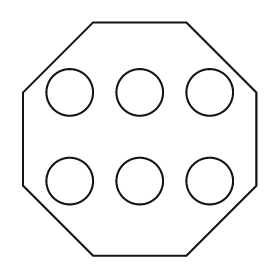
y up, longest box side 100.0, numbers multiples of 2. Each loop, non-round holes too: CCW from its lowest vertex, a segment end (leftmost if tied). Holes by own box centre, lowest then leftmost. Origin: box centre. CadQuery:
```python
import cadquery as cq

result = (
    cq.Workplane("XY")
    .moveTo(-20.0, -50.0)
    .lineTo(20.0, -50.0)
    .lineTo(50.0, -20.0)
    .lineTo(50.0, 20.0)
    .lineTo(20.0, 50.0)
    .lineTo(-20.0, 50.0)
    .lineTo(-50.0, 20.0)
    .lineTo(-50.0, -20.0)
    .close()
    .moveTo(-30.0, -18.0)
    .circle(10.0)
    .moveTo(0.0, -18.0)
    .circle(10.0)
    .moveTo(30.0, -18.0)
    .circle(10.0)
    .moveTo(-30.0, 20.0)
    .circle(10.0)
    .moveTo(0.0, 20.0)
    .circle(10.0)
    .moveTo(30.0, 20.0)
    .circle(10.0)
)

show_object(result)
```